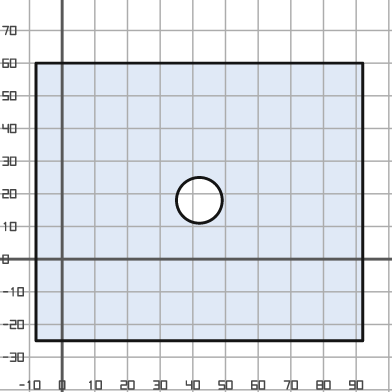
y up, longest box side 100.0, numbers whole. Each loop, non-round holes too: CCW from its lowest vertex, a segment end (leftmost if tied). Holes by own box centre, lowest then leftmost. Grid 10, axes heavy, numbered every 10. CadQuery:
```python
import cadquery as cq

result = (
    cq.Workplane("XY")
    .moveTo(-8.0, -25.0)
    .lineTo(92.0, -25.0)
    .lineTo(92.0, 60.0)
    .lineTo(-8.0, 60.0)
    .close()
    .moveTo(42.0, 18.0)
    .circle(7.0)
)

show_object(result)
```